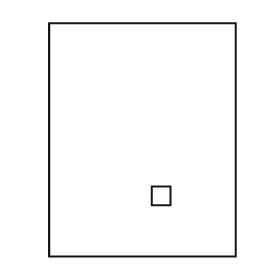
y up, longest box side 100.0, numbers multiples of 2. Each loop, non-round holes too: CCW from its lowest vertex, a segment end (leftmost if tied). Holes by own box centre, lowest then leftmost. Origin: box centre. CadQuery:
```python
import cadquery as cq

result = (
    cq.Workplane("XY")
    .moveTo(-40.0, -50.0)
    .lineTo(40.0, -50.0)
    .lineTo(40.0, 50.0)
    .lineTo(-40.0, 50.0)
    .close()
    .moveTo(4.0, -28.0)
    .lineTo(12.0, -28.0)
    .lineTo(12.0, -20.0)
    .lineTo(4.0, -20.0)
    .close()
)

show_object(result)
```